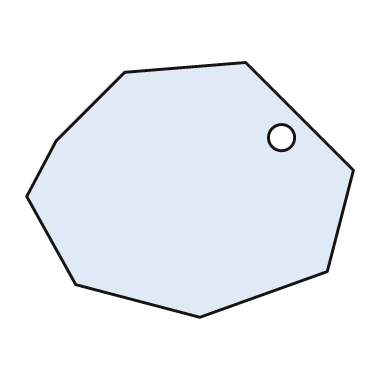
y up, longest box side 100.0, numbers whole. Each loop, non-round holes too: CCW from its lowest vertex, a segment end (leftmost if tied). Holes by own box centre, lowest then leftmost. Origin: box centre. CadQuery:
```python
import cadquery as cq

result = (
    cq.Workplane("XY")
    .moveTo(3.0, -39.0)
    .lineTo(42.0, -25.0)
    .lineTo(50.0, 6.0)
    .lineTo(17.0, 39.0)
    .lineTo(-20.0, 36.0)
    .lineTo(-41.0, 15.0)
    .lineTo(-50.0, -2.0)
    .lineTo(-35.0, -29.0)
    .close()
    .moveTo(28.0, 16.0)
    .circle(4.0)
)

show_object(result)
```